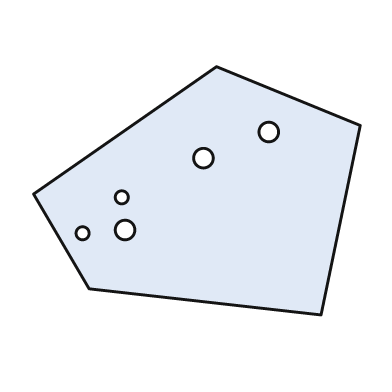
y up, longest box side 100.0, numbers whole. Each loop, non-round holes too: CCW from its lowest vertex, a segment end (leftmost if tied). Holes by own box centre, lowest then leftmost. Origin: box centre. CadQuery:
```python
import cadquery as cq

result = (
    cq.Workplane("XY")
    .moveTo(38.0, -38.0)
    .lineTo(50.0, 20.0)
    .lineTo(6.0, 38.0)
    .lineTo(-50.0, -1.0)
    .lineTo(-33.0, -30.0)
    .close()
    .moveTo(-35.0, -13.0)
    .circle(2.0)
    .moveTo(-22.0, -12.0)
    .circle(3.0)
    .moveTo(-23.0, -2.0)
    .circle(2.0)
    .moveTo(2.0, 10.0)
    .circle(3.0)
    .moveTo(22.0, 18.0)
    .circle(3.0)
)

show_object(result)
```